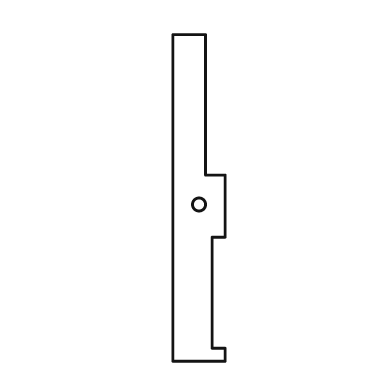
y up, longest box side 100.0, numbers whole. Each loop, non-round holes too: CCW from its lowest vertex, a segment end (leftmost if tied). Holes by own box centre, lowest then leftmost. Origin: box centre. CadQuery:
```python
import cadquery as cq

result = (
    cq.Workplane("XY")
    .moveTo(-8.0, -50.0)
    .lineTo(8.0, -50.0)
    .lineTo(8.0, -46.0)
    .lineTo(4.0, -46.0)
    .lineTo(4.0, -12.0)
    .lineTo(8.0, -12.0)
    .lineTo(8.0, 7.0)
    .lineTo(2.0, 7.0)
    .lineTo(2.0, 50.0)
    .lineTo(-8.0, 50.0)
    .close()
    .moveTo(0.0, -2.0)
    .circle(2.0)
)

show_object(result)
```